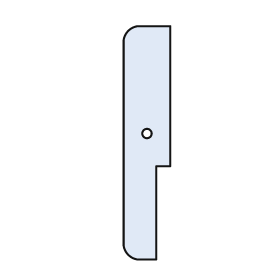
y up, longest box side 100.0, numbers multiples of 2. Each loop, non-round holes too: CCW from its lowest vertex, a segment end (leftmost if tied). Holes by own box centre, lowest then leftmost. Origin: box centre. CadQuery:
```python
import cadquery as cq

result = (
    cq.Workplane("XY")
    .moveTo(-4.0, -50.0)
    .lineTo(4.0, -50.0)
    .lineTo(4.0, -10.0)
    .lineTo(10.0, -10.0)
    .lineTo(10.0, 50.0)
    .lineTo(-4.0, 50.0)
    .threePointArc((-8.0, 48.0), (-10.0, 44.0))
    .lineTo(-10.0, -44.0)
    .threePointArc((-8.0, -48.0), (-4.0, -50.0))
    .close()
    .moveTo(0.0, 4.0)
    .circle(2.0)
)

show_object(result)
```